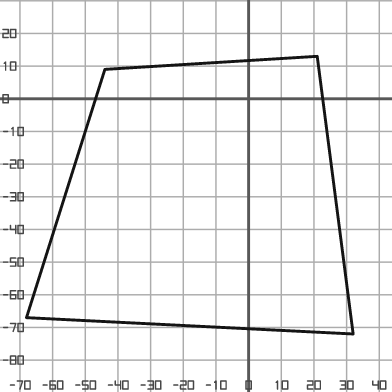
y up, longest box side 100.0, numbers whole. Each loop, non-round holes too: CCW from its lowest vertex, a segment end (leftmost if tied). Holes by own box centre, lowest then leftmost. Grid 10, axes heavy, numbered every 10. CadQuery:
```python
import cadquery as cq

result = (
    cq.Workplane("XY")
    .moveTo(32.0, -72.0)
    .lineTo(21.0, 13.0)
    .lineTo(-44.0, 9.0)
    .lineTo(-68.0, -67.0)
    .close()
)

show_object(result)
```